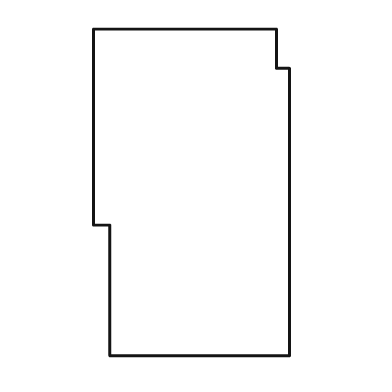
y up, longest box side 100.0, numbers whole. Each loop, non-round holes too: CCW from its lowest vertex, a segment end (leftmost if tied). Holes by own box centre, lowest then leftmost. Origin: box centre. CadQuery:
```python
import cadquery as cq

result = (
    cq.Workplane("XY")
    .moveTo(-25.0, -50.0)
    .lineTo(30.0, -50.0)
    .lineTo(30.0, 38.0)
    .lineTo(26.0, 38.0)
    .lineTo(26.0, 50.0)
    .lineTo(-30.0, 50.0)
    .lineTo(-30.0, -10.0)
    .lineTo(-25.0, -10.0)
    .close()
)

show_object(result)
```